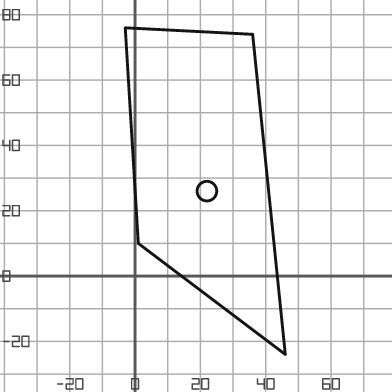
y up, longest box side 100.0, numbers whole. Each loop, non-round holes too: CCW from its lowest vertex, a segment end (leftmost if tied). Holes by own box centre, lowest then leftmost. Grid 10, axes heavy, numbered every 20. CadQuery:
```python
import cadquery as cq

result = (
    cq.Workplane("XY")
    .moveTo(46.0, -24.0)
    .lineTo(36.0, 74.0)
    .lineTo(-3.0, 76.0)
    .lineTo(1.0, 10.0)
    .close()
    .moveTo(22.0, 26.0)
    .circle(3.0)
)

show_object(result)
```